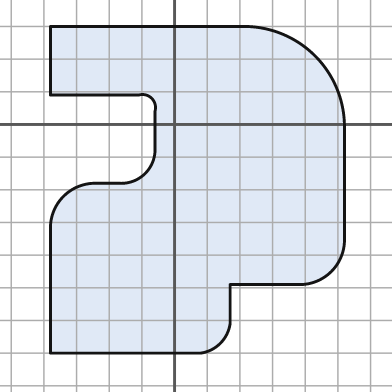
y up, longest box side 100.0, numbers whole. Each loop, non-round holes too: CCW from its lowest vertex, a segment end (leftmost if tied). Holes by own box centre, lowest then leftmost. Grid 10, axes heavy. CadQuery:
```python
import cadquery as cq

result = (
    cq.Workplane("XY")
    .moveTo(-38.0, -70.0)
    .lineTo(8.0, -70.0)
    .threePointArc((14.0, -67.0), (17.0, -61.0))
    .lineTo(17.0, -49.0)
    .lineTo(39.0, -49.0)
    .threePointArc((48.0, -45.0), (52.0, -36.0))
    .lineTo(52.0, 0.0)
    .threePointArc((43.0, 21.0), (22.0, 30.0))
    .lineTo(-38.0, 30.0)
    .lineTo(-38.0, 9.0)
    .lineTo(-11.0, 9.0)
    .threePointArc((-7.0, 8.0), (-6.0, 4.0))
    .lineTo(-6.0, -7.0)
    .threePointArc((-9.0, -15.0), (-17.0, -18.0))
    .lineTo(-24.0, -18.0)
    .threePointArc((-34.0, -22.0), (-38.0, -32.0))
    .close()
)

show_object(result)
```